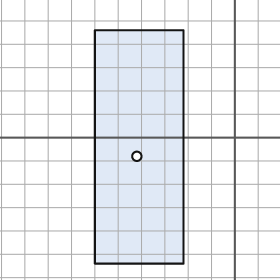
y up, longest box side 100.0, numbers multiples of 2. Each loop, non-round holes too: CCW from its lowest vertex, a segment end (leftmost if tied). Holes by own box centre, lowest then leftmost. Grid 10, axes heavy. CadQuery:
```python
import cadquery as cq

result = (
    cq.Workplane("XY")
    .moveTo(-60.0, -54.0)
    .lineTo(-22.0, -54.0)
    .lineTo(-22.0, 46.0)
    .lineTo(-60.0, 46.0)
    .close()
    .moveTo(-42.0, -8.0)
    .circle(2.0)
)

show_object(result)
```